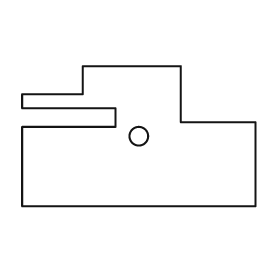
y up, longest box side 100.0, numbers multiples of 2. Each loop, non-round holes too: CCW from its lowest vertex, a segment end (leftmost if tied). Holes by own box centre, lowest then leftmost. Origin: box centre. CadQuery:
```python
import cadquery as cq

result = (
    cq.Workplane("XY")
    .moveTo(-50.0, -30.0)
    .lineTo(50.0, -30.0)
    .lineTo(50.0, 6.0)
    .lineTo(18.0, 6.0)
    .lineTo(18.0, 30.0)
    .lineTo(-24.0, 30.0)
    .lineTo(-24.0, 18.0)
    .lineTo(-50.0, 18.0)
    .lineTo(-50.0, 12.0)
    .lineTo(-10.0, 12.0)
    .lineTo(-10.0, 4.0)
    .lineTo(-50.0, 4.0)
    .close()
    .moveTo(0.0, 0.0)
    .circle(4.0)
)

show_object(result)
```